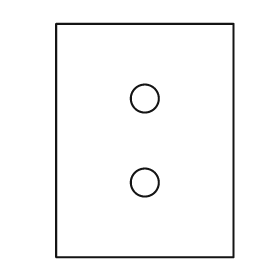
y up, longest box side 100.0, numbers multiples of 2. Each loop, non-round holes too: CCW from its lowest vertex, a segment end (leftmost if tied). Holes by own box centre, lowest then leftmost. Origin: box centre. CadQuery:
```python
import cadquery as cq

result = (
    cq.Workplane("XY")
    .moveTo(-38.0, -50.0)
    .lineTo(38.0, -50.0)
    .lineTo(38.0, 50.0)
    .lineTo(-38.0, 50.0)
    .close()
    .moveTo(0.0, -18.0)
    .circle(6.0)
    .moveTo(0.0, 18.0)
    .circle(6.0)
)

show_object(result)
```